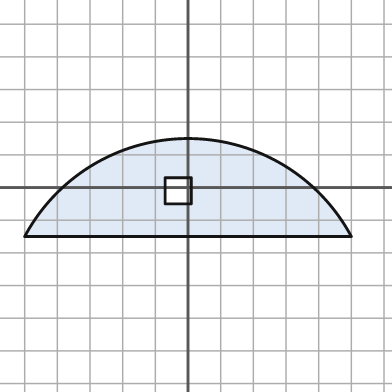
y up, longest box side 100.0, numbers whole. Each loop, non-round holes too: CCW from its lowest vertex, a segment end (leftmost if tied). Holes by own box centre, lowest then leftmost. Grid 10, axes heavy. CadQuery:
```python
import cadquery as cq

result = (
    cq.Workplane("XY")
    .moveTo(-50.0, -15.0)
    .lineTo(50.0, -15.0)
    .threePointArc((0.0, 15.0), (-50.0, -15.0))
    .close()
    .moveTo(-7.0, -5.0)
    .lineTo(1.0, -5.0)
    .lineTo(1.0, 3.0)
    .lineTo(-7.0, 3.0)
    .close()
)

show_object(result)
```